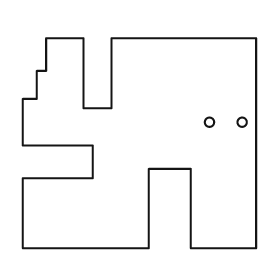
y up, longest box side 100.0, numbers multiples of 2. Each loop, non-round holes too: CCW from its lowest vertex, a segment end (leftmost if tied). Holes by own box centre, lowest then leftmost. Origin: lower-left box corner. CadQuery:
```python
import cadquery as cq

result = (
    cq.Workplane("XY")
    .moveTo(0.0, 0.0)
    .lineTo(54.0, 0.0)
    .lineTo(54.0, 34.0)
    .lineTo(72.0, 34.0)
    .lineTo(72.0, 0.0)
    .lineTo(100.0, 0.0)
    .lineTo(100.0, 90.0)
    .lineTo(38.0, 90.0)
    .lineTo(38.0, 60.0)
    .lineTo(26.0, 60.0)
    .lineTo(26.0, 90.0)
    .lineTo(10.0, 90.0)
    .lineTo(10.0, 76.0)
    .lineTo(6.0, 76.0)
    .lineTo(6.0, 64.0)
    .lineTo(0.0, 64.0)
    .lineTo(0.0, 44.0)
    .lineTo(30.0, 44.0)
    .lineTo(30.0, 30.0)
    .lineTo(0.0, 30.0)
    .close()
    .moveTo(80.0, 54.0)
    .circle(2.0)
    .moveTo(94.0, 54.0)
    .circle(2.0)
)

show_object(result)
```